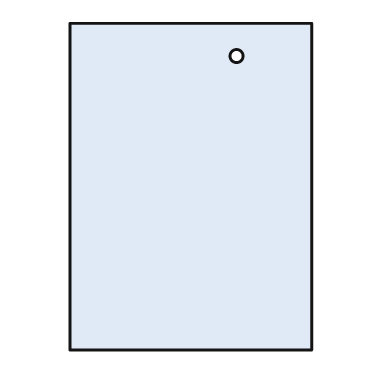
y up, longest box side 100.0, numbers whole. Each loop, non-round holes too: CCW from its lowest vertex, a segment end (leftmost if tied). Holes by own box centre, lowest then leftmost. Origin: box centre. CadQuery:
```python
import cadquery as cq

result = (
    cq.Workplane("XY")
    .moveTo(-37.0, -50.0)
    .lineTo(37.0, -50.0)
    .lineTo(37.0, 50.0)
    .lineTo(-37.0, 50.0)
    .close()
    .moveTo(14.0, 40.0)
    .circle(2.0)
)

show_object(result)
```